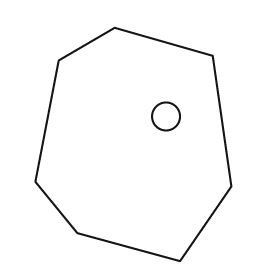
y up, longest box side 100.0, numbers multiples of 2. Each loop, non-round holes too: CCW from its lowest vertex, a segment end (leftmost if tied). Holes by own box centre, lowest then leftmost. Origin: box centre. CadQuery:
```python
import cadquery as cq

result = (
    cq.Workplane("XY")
    .moveTo(20.0, -50.0)
    .lineTo(42.0, -18.0)
    .lineTo(34.0, 38.0)
    .lineTo(-8.0, 50.0)
    .lineTo(-32.0, 36.0)
    .lineTo(-42.0, -16.0)
    .lineTo(-24.0, -38.0)
    .close()
    .moveTo(14.0, 12.0)
    .circle(6.0)
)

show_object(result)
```